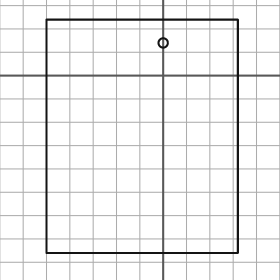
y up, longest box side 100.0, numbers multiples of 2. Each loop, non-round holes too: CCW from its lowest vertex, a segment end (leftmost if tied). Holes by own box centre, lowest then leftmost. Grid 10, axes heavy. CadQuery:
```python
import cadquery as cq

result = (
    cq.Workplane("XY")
    .moveTo(-50.0, -76.0)
    .lineTo(32.0, -76.0)
    .lineTo(32.0, 24.0)
    .lineTo(-50.0, 24.0)
    .close()
    .moveTo(0.0, 14.0)
    .circle(2.0)
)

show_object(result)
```